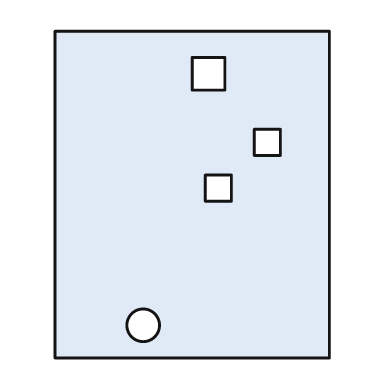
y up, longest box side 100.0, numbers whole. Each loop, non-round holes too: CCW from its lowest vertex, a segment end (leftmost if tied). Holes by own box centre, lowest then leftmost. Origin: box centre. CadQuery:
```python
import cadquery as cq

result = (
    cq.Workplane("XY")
    .moveTo(-42.0, -50.0)
    .lineTo(42.0, -50.0)
    .lineTo(42.0, 50.0)
    .lineTo(-42.0, 50.0)
    .close()
    .moveTo(-15.0, -40.0)
    .circle(5.0)
    .moveTo(4.0, -2.0)
    .lineTo(12.0, -2.0)
    .lineTo(12.0, 6.0)
    .lineTo(4.0, 6.0)
    .close()
    .moveTo(19.0, 12.0)
    .lineTo(27.0, 12.0)
    .lineTo(27.0, 20.0)
    .lineTo(19.0, 20.0)
    .close()
    .moveTo(0.0, 32.0)
    .lineTo(10.0, 32.0)
    .lineTo(10.0, 42.0)
    .lineTo(0.0, 42.0)
    .close()
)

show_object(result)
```